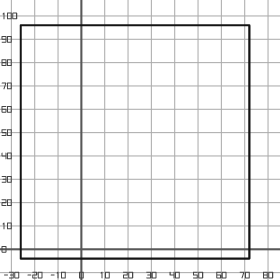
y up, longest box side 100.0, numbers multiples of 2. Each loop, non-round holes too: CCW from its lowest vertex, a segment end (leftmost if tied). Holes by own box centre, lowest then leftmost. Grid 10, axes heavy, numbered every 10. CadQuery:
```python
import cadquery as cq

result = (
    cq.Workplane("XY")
    .moveTo(-26.0, -4.0)
    .lineTo(72.0, -4.0)
    .lineTo(72.0, 96.0)
    .lineTo(-26.0, 96.0)
    .close()
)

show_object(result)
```